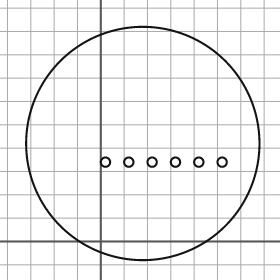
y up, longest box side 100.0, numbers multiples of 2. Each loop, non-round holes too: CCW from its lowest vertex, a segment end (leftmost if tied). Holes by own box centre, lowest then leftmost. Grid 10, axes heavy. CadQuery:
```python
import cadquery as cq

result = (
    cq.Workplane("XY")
    .moveTo(18.0, 42.0)
    .circle(50.0)
    .moveTo(2.0, 34.0)
    .circle(2.0)
    .moveTo(12.0, 34.0)
    .circle(2.0)
    .moveTo(22.0, 34.0)
    .circle(2.0)
    .moveTo(32.0, 34.0)
    .circle(2.0)
    .moveTo(42.0, 34.0)
    .circle(2.0)
    .moveTo(52.0, 34.0)
    .circle(2.0)
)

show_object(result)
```